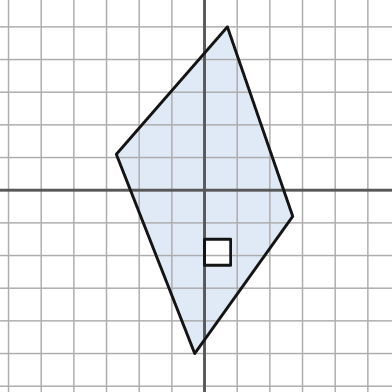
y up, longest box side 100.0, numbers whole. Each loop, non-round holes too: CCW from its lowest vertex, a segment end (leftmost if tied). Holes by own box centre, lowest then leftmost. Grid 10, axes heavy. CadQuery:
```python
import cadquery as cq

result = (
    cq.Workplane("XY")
    .moveTo(-3.0, -50.0)
    .lineTo(27.0, -8.0)
    .lineTo(7.0, 50.0)
    .lineTo(-27.0, 11.0)
    .close()
    .moveTo(0.0, -23.0)
    .lineTo(8.0, -23.0)
    .lineTo(8.0, -15.0)
    .lineTo(0.0, -15.0)
    .close()
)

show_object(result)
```